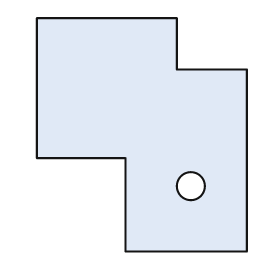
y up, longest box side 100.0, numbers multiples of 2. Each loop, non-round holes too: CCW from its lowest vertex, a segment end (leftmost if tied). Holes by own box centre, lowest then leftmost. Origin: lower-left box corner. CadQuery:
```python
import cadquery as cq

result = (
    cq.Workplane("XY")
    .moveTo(38.0, 0.0)
    .lineTo(90.0, 0.0)
    .lineTo(90.0, 78.0)
    .lineTo(60.0, 78.0)
    .lineTo(60.0, 100.0)
    .lineTo(0.0, 100.0)
    .lineTo(0.0, 40.0)
    .lineTo(38.0, 40.0)
    .close()
    .moveTo(66.0, 28.0)
    .circle(6.0)
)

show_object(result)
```